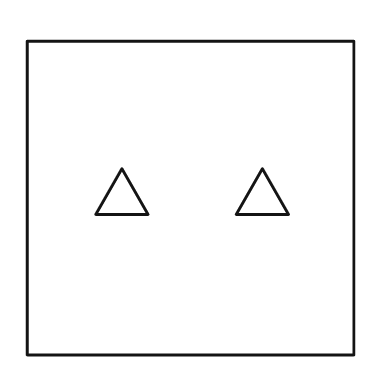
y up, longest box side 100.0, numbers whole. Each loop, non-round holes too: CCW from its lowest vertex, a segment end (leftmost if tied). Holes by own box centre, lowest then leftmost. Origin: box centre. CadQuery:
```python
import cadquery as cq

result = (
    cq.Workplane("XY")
    .moveTo(-50.0, -48.0)
    .lineTo(50.0, -48.0)
    .lineTo(50.0, 48.0)
    .lineTo(-50.0, 48.0)
    .close()
    .moveTo(-29.0, -5.0)
    .lineTo(-13.0, -5.0)
    .lineTo(-21.0, 9.0)
    .close()
    .moveTo(14.0, -5.0)
    .lineTo(30.0, -5.0)
    .lineTo(22.0, 9.0)
    .close()
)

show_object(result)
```